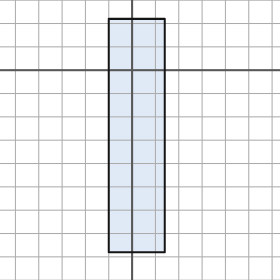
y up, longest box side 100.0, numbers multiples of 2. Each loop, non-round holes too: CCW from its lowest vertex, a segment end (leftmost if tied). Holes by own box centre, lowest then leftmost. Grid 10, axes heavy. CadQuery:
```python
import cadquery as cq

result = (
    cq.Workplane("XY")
    .moveTo(-10.0, -78.0)
    .lineTo(14.0, -78.0)
    .lineTo(14.0, 22.0)
    .lineTo(-10.0, 22.0)
    .close()
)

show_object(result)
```